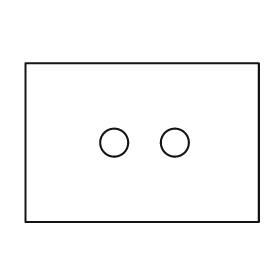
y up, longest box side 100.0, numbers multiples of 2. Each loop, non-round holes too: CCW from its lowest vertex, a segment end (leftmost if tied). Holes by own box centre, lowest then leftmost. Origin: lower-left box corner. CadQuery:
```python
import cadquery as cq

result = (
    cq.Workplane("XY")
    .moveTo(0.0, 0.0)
    .lineTo(100.0, 0.0)
    .lineTo(100.0, 68.0)
    .lineTo(0.0, 68.0)
    .close()
    .moveTo(38.0, 34.0)
    .circle(6.0)
    .moveTo(64.0, 34.0)
    .circle(6.0)
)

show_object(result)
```